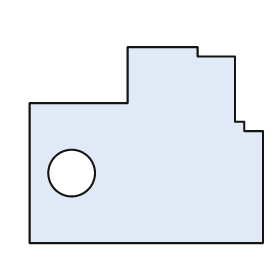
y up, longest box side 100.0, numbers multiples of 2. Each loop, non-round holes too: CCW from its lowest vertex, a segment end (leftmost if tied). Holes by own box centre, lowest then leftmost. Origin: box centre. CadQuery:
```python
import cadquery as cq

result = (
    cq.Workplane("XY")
    .moveTo(-50.0, -42.0)
    .lineTo(50.0, -42.0)
    .lineTo(50.0, 6.0)
    .lineTo(42.0, 6.0)
    .lineTo(42.0, 10.0)
    .lineTo(38.0, 10.0)
    .lineTo(38.0, 38.0)
    .lineTo(22.0, 38.0)
    .lineTo(22.0, 42.0)
    .lineTo(-8.0, 42.0)
    .lineTo(-8.0, 18.0)
    .lineTo(-50.0, 18.0)
    .close()
    .moveTo(-32.0, -12.0)
    .circle(10.0)
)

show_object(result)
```